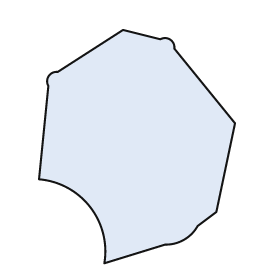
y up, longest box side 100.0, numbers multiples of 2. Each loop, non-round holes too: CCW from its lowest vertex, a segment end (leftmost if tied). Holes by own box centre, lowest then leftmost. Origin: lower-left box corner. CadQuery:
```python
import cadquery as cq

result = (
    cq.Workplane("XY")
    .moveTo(28.0, 0.0)
    .lineTo(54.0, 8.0)
    .threePointArc((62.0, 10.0), (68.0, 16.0))
    .lineTo(76.0, 22.0)
    .lineTo(84.0, 60.0)
    .lineTo(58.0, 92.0)
    .threePointArc((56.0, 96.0), (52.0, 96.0))
    .lineTo(36.0, 100.0)
    .lineTo(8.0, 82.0)
    .threePointArc((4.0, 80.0), (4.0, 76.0))
    .lineTo(0.0, 36.0)
    .threePointArc((22.0, 24.0), (28.0, 0.0))
    .close()
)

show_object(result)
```